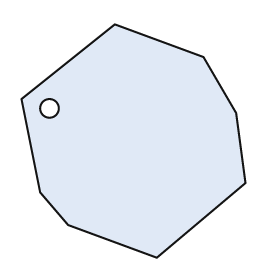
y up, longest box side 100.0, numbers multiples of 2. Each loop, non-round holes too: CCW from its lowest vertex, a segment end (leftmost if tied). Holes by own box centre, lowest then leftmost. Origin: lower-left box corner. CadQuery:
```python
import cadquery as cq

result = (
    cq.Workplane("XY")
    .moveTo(58.0, 0.0)
    .lineTo(96.0, 32.0)
    .lineTo(92.0, 62.0)
    .lineTo(78.0, 86.0)
    .lineTo(40.0, 100.0)
    .lineTo(0.0, 68.0)
    .lineTo(8.0, 28.0)
    .lineTo(20.0, 14.0)
    .close()
    .moveTo(12.0, 64.0)
    .circle(4.0)
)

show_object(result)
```